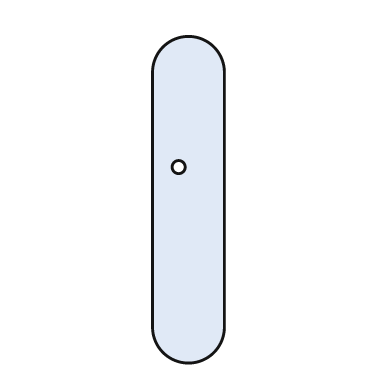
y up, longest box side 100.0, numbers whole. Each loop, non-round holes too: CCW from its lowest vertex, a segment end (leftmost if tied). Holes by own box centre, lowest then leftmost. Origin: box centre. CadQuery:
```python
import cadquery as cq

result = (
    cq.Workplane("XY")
    .moveTo(-11.0, -39.0)
    .threePointArc((0.0, -50.0), (11.0, -39.0))
    .lineTo(11.0, 39.0)
    .threePointArc((0.0, 50.0), (-11.0, 39.0))
    .close()
    .moveTo(-3.0, 10.0)
    .circle(2.0)
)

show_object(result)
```